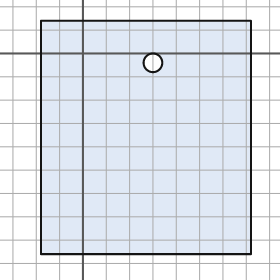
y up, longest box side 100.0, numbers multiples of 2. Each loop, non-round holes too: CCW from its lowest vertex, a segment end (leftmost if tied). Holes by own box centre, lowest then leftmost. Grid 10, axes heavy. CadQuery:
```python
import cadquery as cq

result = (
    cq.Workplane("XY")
    .moveTo(-18.0, -86.0)
    .lineTo(72.0, -86.0)
    .lineTo(72.0, 14.0)
    .lineTo(-18.0, 14.0)
    .close()
    .moveTo(30.0, -4.0)
    .circle(4.0)
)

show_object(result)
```